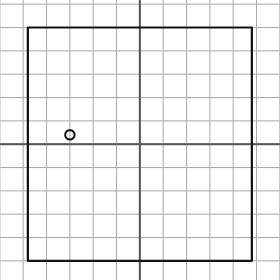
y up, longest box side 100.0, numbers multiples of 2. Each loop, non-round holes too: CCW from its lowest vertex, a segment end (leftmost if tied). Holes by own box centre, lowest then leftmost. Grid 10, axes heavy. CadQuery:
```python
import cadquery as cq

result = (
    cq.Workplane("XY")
    .moveTo(-48.0, -50.0)
    .lineTo(48.0, -50.0)
    .lineTo(48.0, 50.0)
    .lineTo(-48.0, 50.0)
    .close()
    .moveTo(-30.0, 4.0)
    .circle(2.0)
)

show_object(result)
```